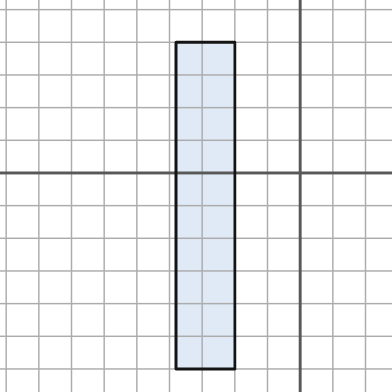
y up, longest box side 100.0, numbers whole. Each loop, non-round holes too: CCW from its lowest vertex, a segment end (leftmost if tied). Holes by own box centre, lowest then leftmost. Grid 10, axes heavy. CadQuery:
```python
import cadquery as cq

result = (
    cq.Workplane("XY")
    .moveTo(-38.0, -60.0)
    .lineTo(-20.0, -60.0)
    .lineTo(-20.0, 40.0)
    .lineTo(-38.0, 40.0)
    .close()
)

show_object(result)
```